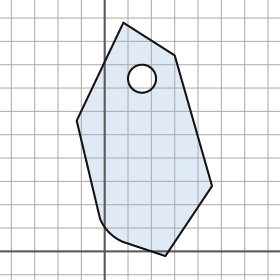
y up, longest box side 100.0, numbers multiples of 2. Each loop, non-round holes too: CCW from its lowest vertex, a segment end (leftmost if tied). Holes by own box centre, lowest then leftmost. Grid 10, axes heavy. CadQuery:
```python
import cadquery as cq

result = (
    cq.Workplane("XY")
    .moveTo(26.0, -2.0)
    .lineTo(46.0, 28.0)
    .lineTo(30.0, 84.0)
    .lineTo(8.0, 98.0)
    .lineTo(-12.0, 56.0)
    .lineTo(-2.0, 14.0)
    .threePointArc((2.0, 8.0), (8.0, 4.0))
    .close()
    .moveTo(16.0, 74.0)
    .circle(6.0)
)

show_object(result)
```